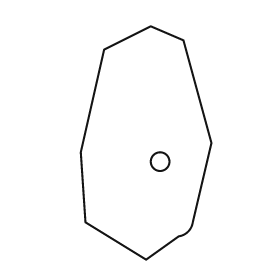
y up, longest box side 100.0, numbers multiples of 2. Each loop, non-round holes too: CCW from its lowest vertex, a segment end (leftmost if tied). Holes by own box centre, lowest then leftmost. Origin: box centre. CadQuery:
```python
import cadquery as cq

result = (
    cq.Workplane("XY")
    .moveTo(0.0, -50.0)
    .lineTo(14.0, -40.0)
    .threePointArc((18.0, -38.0), (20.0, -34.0))
    .lineTo(28.0, 0.0)
    .lineTo(16.0, 44.0)
    .lineTo(2.0, 50.0)
    .lineTo(-18.0, 40.0)
    .lineTo(-28.0, -4.0)
    .lineTo(-26.0, -34.0)
    .close()
    .moveTo(6.0, -8.0)
    .circle(4.0)
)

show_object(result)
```